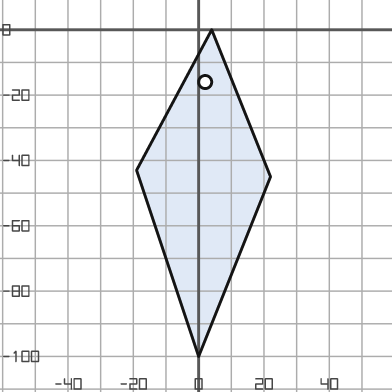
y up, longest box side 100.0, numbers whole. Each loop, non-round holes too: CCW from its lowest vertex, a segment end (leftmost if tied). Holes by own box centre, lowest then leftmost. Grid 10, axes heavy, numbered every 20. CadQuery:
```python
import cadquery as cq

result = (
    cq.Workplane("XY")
    .moveTo(0.0, -100.0)
    .lineTo(22.0, -45.0)
    .lineTo(4.0, 0.0)
    .lineTo(-19.0, -43.0)
    .close()
    .moveTo(2.0, -16.0)
    .circle(2.0)
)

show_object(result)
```